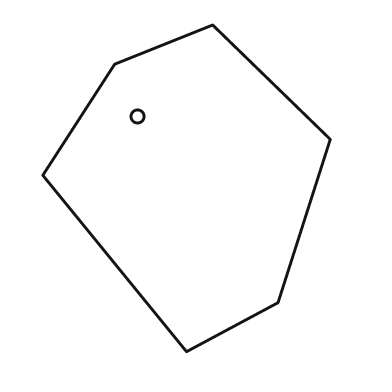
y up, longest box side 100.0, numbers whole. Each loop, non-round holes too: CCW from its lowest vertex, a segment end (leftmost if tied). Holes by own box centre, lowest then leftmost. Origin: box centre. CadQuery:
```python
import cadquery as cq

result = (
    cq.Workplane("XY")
    .moveTo(0.0, -50.0)
    .lineTo(28.0, -35.0)
    .lineTo(44.0, 15.0)
    .lineTo(8.0, 50.0)
    .lineTo(-22.0, 38.0)
    .lineTo(-44.0, 4.0)
    .close()
    .moveTo(-15.0, 22.0)
    .circle(2.0)
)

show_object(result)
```